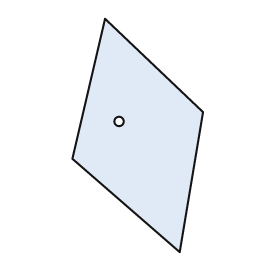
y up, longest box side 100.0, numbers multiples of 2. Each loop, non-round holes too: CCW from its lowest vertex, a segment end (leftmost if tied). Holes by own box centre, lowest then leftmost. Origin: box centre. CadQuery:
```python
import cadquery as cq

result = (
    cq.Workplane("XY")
    .moveTo(18.0, -50.0)
    .lineTo(28.0, 10.0)
    .lineTo(-14.0, 50.0)
    .lineTo(-28.0, -10.0)
    .close()
    .moveTo(-8.0, 6.0)
    .circle(2.0)
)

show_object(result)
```